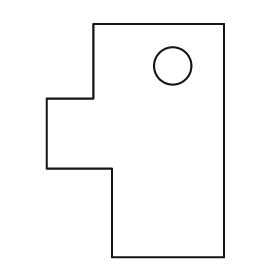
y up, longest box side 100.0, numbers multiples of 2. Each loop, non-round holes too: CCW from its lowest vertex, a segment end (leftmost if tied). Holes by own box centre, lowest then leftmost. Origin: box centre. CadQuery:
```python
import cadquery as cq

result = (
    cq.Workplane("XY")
    .moveTo(-10.0, -50.0)
    .lineTo(38.0, -50.0)
    .lineTo(38.0, 50.0)
    .lineTo(-18.0, 50.0)
    .lineTo(-18.0, 18.0)
    .lineTo(-38.0, 18.0)
    .lineTo(-38.0, -12.0)
    .lineTo(-10.0, -12.0)
    .close()
    .moveTo(16.0, 32.0)
    .circle(8.0)
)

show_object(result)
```